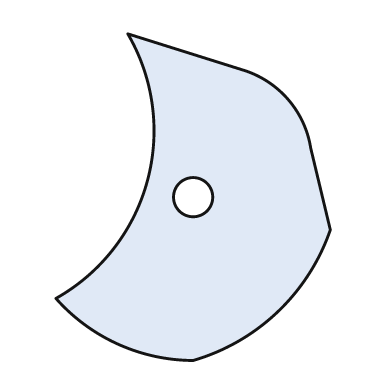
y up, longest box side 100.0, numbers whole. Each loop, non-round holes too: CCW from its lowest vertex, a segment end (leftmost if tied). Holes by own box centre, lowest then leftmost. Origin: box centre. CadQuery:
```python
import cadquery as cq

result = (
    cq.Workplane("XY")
    .moveTo(0.0, -50.0)
    .threePointArc((26.0, -35.0), (42.0, -10.0))
    .lineTo(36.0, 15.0)
    .threePointArc((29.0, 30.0), (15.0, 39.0))
    .lineTo(-20.0, 50.0)
    .threePointArc((-14.0, 5.0), (-42.0, -31.0))
    .threePointArc((-23.0, -45.0), (0.0, -50.0))
    .close()
    .moveTo(0.0, 0.0)
    .circle(6.0)
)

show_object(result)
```